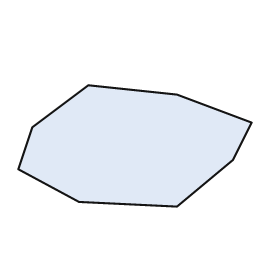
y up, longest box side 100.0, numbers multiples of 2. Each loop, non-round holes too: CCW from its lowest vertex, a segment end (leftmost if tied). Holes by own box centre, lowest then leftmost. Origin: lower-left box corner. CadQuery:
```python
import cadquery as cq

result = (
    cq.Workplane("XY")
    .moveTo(68.0, 0.0)
    .lineTo(92.0, 20.0)
    .lineTo(100.0, 36.0)
    .lineTo(68.0, 48.0)
    .lineTo(30.0, 52.0)
    .lineTo(6.0, 34.0)
    .lineTo(0.0, 16.0)
    .lineTo(26.0, 2.0)
    .close()
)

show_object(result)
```